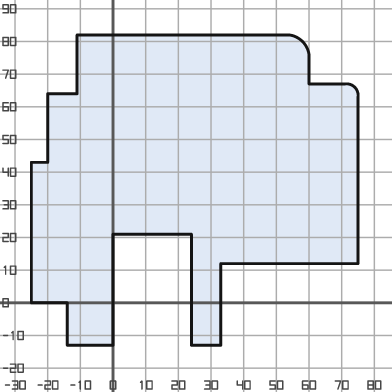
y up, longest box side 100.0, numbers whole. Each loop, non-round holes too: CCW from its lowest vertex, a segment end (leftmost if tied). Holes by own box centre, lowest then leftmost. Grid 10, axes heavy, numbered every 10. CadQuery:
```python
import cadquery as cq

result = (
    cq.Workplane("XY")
    .moveTo(-14.0, -13.0)
    .lineTo(0.0, -13.0)
    .lineTo(0.0, 21.0)
    .lineTo(24.0, 21.0)
    .lineTo(24.0, -13.0)
    .lineTo(33.0, -13.0)
    .lineTo(33.0, 12.0)
    .lineTo(75.0, 12.0)
    .lineTo(75.0, 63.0)
    .threePointArc((74.0, 66.0), (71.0, 67.0))
    .lineTo(60.0, 67.0)
    .lineTo(60.0, 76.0)
    .threePointArc((58.0, 80.0), (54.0, 82.0))
    .lineTo(-11.0, 82.0)
    .lineTo(-11.0, 64.0)
    .lineTo(-20.0, 64.0)
    .lineTo(-20.0, 43.0)
    .lineTo(-25.0, 43.0)
    .lineTo(-25.0, 0.0)
    .lineTo(-14.0, 0.0)
    .close()
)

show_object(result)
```